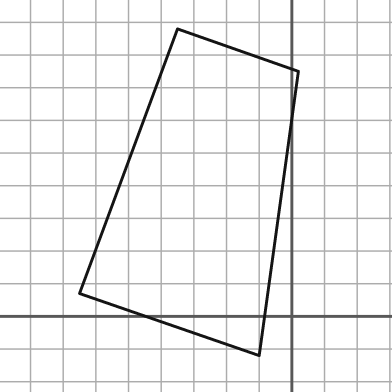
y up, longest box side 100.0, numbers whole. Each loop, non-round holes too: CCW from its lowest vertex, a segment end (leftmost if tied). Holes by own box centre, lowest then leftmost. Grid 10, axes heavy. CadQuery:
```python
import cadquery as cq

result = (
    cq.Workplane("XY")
    .moveTo(-10.0, -12.0)
    .lineTo(2.0, 75.0)
    .lineTo(-35.0, 88.0)
    .lineTo(-65.0, 7.0)
    .close()
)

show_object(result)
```